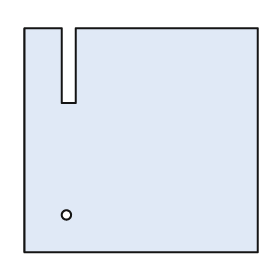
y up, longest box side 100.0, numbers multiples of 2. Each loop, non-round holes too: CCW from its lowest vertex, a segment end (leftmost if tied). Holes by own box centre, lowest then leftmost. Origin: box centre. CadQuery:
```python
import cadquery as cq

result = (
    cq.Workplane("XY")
    .moveTo(-50.0, -48.0)
    .lineTo(50.0, -48.0)
    .lineTo(50.0, 48.0)
    .lineTo(-28.0, 48.0)
    .lineTo(-28.0, 16.0)
    .lineTo(-34.0, 16.0)
    .lineTo(-34.0, 48.0)
    .lineTo(-50.0, 48.0)
    .close()
    .moveTo(-32.0, -32.0)
    .circle(2.0)
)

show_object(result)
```